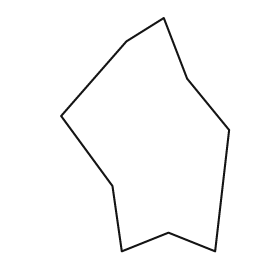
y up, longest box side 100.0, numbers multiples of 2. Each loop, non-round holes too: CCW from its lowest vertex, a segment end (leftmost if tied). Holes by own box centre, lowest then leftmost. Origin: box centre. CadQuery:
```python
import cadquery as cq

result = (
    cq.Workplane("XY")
    .moveTo(-10.0, -50.0)
    .lineTo(10.0, -42.0)
    .lineTo(30.0, -50.0)
    .lineTo(36.0, 2.0)
    .lineTo(18.0, 24.0)
    .lineTo(8.0, 50.0)
    .lineTo(-8.0, 40.0)
    .lineTo(-36.0, 8.0)
    .lineTo(-14.0, -22.0)
    .close()
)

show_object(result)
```